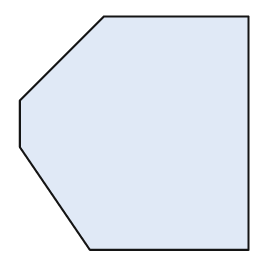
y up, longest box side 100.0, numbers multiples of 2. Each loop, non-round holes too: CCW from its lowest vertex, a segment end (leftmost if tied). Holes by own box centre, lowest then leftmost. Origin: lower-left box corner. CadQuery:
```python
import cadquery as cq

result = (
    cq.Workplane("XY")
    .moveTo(30.0, 0.0)
    .lineTo(98.0, 0.0)
    .lineTo(98.0, 100.0)
    .lineTo(36.0, 100.0)
    .lineTo(0.0, 64.0)
    .lineTo(0.0, 44.0)
    .close()
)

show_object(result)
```